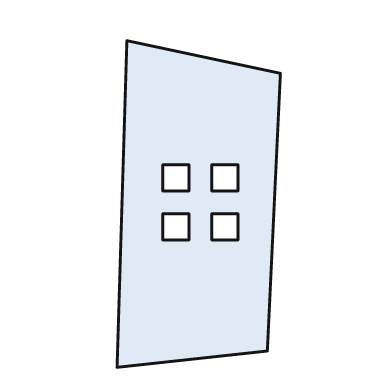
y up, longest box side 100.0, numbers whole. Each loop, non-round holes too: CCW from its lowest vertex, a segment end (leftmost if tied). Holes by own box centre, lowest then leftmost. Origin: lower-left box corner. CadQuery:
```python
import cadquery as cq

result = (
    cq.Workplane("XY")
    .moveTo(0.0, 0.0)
    .lineTo(46.0, 5.0)
    .lineTo(50.0, 90.0)
    .lineTo(3.0, 100.0)
    .close()
    .moveTo(14.0, 39.0)
    .lineTo(22.0, 39.0)
    .lineTo(22.0, 47.0)
    .lineTo(14.0, 47.0)
    .close()
    .moveTo(29.0, 39.0)
    .lineTo(37.0, 39.0)
    .lineTo(37.0, 47.0)
    .lineTo(29.0, 47.0)
    .close()
    .moveTo(14.0, 54.0)
    .lineTo(22.0, 54.0)
    .lineTo(22.0, 62.0)
    .lineTo(14.0, 62.0)
    .close()
    .moveTo(29.0, 54.0)
    .lineTo(37.0, 54.0)
    .lineTo(37.0, 62.0)
    .lineTo(29.0, 62.0)
    .close()
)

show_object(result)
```